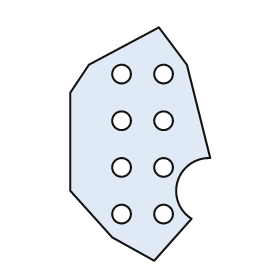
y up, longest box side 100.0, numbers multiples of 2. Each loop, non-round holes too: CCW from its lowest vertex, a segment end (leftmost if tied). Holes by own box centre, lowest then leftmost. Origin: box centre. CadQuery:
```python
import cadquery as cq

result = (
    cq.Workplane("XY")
    .moveTo(6.0, -50.0)
    .lineTo(22.0, -32.0)
    .threePointArc((16.0, -16.0), (30.0, -6.0))
    .lineTo(20.0, 34.0)
    .lineTo(8.0, 50.0)
    .lineTo(-22.0, 34.0)
    .lineTo(-30.0, 22.0)
    .lineTo(-30.0, -20.0)
    .lineTo(-12.0, -40.0)
    .close()
    .moveTo(-8.0, -30.0)
    .circle(4.0)
    .moveTo(10.0, -30.0)
    .circle(4.0)
    .moveTo(-8.0, -10.0)
    .circle(4.0)
    .moveTo(10.0, -10.0)
    .circle(4.0)
    .moveTo(-8.0, 10.0)
    .circle(4.0)
    .moveTo(10.0, 10.0)
    .circle(4.0)
    .moveTo(-8.0, 30.0)
    .circle(4.0)
    .moveTo(10.0, 30.0)
    .circle(4.0)
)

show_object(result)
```